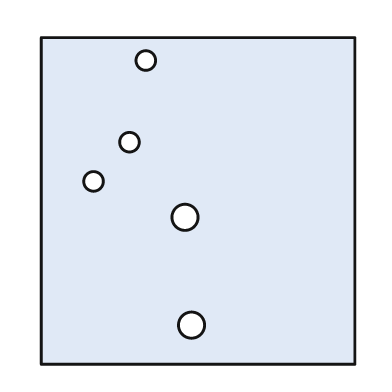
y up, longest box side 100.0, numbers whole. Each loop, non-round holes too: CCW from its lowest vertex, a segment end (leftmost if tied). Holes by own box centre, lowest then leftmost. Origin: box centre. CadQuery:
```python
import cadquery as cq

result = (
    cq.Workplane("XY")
    .moveTo(-48.0, -50.0)
    .lineTo(48.0, -50.0)
    .lineTo(48.0, 50.0)
    .lineTo(-48.0, 50.0)
    .close()
    .moveTo(-2.0, -38.0)
    .circle(4.0)
    .moveTo(-4.0, -5.0)
    .circle(4.0)
    .moveTo(-32.0, 6.0)
    .circle(3.0)
    .moveTo(-21.0, 18.0)
    .circle(3.0)
    .moveTo(-16.0, 43.0)
    .circle(3.0)
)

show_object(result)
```